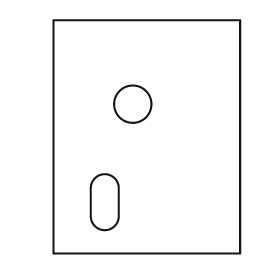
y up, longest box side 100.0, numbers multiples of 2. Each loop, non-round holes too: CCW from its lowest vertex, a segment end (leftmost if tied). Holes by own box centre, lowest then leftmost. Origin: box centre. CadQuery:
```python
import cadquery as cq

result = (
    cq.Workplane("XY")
    .moveTo(-40.0, -50.0)
    .lineTo(40.0, -50.0)
    .lineTo(40.0, 50.0)
    .lineTo(-40.0, 50.0)
    .close()
    .moveTo(-24.0, -34.0)
    .threePointArc((-18.0, -40.0), (-12.0, -34.0))
    .lineTo(-12.0, -22.0)
    .threePointArc((-18.0, -16.0), (-24.0, -22.0))
    .close()
    .moveTo(-6.0, 14.0)
    .circle(8.0)
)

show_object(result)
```